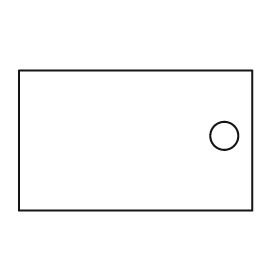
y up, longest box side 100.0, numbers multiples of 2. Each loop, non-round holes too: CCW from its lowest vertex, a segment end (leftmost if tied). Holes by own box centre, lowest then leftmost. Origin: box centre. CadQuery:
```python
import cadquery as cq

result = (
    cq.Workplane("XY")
    .moveTo(-50.0, -30.0)
    .lineTo(50.0, -30.0)
    .lineTo(50.0, 30.0)
    .lineTo(-50.0, 30.0)
    .close()
    .moveTo(38.0, 2.0)
    .circle(6.0)
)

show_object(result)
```